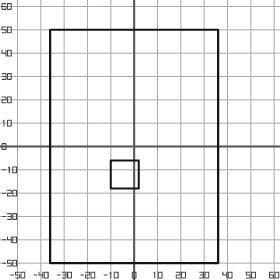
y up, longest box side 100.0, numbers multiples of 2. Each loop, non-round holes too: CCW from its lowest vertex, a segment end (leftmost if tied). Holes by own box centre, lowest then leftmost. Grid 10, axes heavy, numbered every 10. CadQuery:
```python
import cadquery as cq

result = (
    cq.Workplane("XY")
    .moveTo(-36.0, -50.0)
    .lineTo(36.0, -50.0)
    .lineTo(36.0, 50.0)
    .lineTo(-36.0, 50.0)
    .close()
    .moveTo(-10.0, -18.0)
    .lineTo(2.0, -18.0)
    .lineTo(2.0, -6.0)
    .lineTo(-10.0, -6.0)
    .close()
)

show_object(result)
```